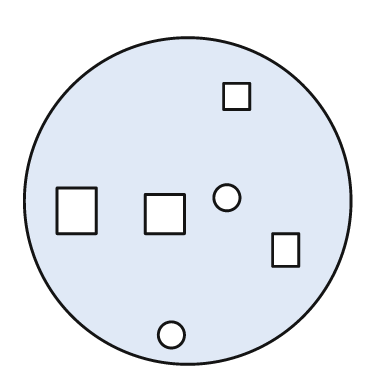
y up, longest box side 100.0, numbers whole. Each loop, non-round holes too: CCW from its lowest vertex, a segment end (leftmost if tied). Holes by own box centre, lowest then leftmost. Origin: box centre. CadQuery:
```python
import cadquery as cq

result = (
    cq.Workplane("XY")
    .moveTo(0.0, 0.0)
    .circle(50.0)
    .moveTo(-5.0, -41.0)
    .circle(4.0)
    .moveTo(26.0, -20.0)
    .lineTo(34.0, -20.0)
    .lineTo(34.0, -10.0)
    .lineTo(26.0, -10.0)
    .close()
    .moveTo(-13.0, -10.0)
    .lineTo(-1.0, -10.0)
    .lineTo(-1.0, 2.0)
    .lineTo(-13.0, 2.0)
    .close()
    .moveTo(-40.0, -10.0)
    .lineTo(-28.0, -10.0)
    .lineTo(-28.0, 4.0)
    .lineTo(-40.0, 4.0)
    .close()
    .moveTo(12.0, 1.0)
    .circle(4.0)
    .moveTo(11.0, 28.0)
    .lineTo(19.0, 28.0)
    .lineTo(19.0, 36.0)
    .lineTo(11.0, 36.0)
    .close()
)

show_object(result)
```